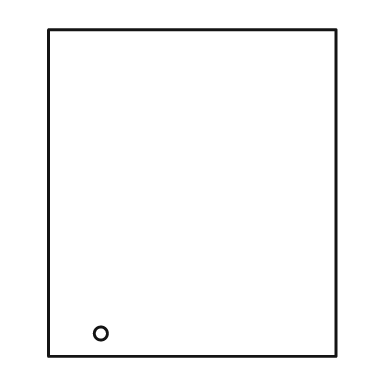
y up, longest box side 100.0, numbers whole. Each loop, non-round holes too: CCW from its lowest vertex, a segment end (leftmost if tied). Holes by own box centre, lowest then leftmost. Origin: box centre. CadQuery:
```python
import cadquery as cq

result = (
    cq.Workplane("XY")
    .moveTo(-44.0, -50.0)
    .lineTo(44.0, -50.0)
    .lineTo(44.0, 50.0)
    .lineTo(-44.0, 50.0)
    .close()
    .moveTo(-28.0, -43.0)
    .circle(2.0)
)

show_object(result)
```